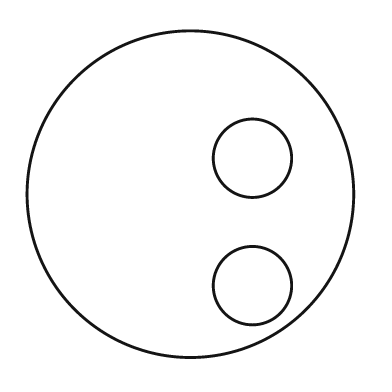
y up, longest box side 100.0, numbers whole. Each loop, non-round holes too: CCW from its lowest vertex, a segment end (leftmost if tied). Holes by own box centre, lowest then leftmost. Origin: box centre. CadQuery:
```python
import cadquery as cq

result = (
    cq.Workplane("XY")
    .moveTo(0.0, 0.0)
    .circle(50.0)
    .moveTo(19.0, -28.0)
    .circle(12.0)
    .moveTo(19.0, 11.0)
    .circle(12.0)
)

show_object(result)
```